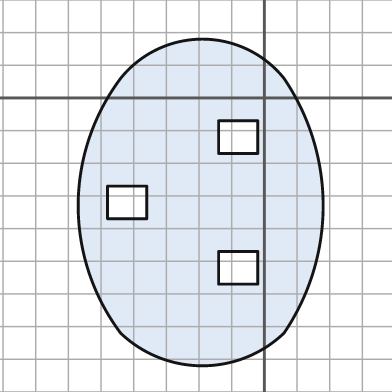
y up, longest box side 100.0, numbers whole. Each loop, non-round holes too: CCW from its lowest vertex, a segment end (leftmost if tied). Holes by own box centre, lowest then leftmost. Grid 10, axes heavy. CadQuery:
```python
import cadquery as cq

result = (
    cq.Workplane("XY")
    .moveTo(-44.0, -72.0)
    .threePointArc((-19.0, -82.0), (6.0, -72.0))
    .threePointArc((18.0, -33.0), (6.0, 6.0))
    .threePointArc((-19.0, 18.0), (-44.0, 6.0))
    .threePointArc((-57.0, -33.0), (-44.0, -72.0))
    .close()
    .moveTo(-14.0, -57.0)
    .lineTo(-2.0, -57.0)
    .lineTo(-2.0, -47.0)
    .lineTo(-14.0, -47.0)
    .close()
    .moveTo(-48.0, -37.0)
    .lineTo(-36.0, -37.0)
    .lineTo(-36.0, -27.0)
    .lineTo(-48.0, -27.0)
    .close()
    .moveTo(-14.0, -17.0)
    .lineTo(-2.0, -17.0)
    .lineTo(-2.0, -7.0)
    .lineTo(-14.0, -7.0)
    .close()
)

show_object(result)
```